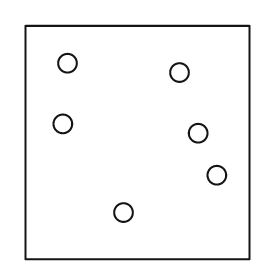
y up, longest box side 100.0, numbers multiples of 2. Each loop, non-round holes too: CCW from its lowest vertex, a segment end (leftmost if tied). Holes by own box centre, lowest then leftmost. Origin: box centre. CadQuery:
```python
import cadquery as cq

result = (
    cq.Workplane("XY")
    .moveTo(-48.0, -50.0)
    .lineTo(48.0, -50.0)
    .lineTo(48.0, 50.0)
    .lineTo(-48.0, 50.0)
    .close()
    .moveTo(-6.0, -30.0)
    .circle(4.0)
    .moveTo(34.0, -14.0)
    .circle(4.0)
    .moveTo(26.0, 4.0)
    .circle(4.0)
    .moveTo(-32.0, 8.0)
    .circle(4.0)
    .moveTo(18.0, 30.0)
    .circle(4.0)
    .moveTo(-30.0, 34.0)
    .circle(4.0)
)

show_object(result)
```